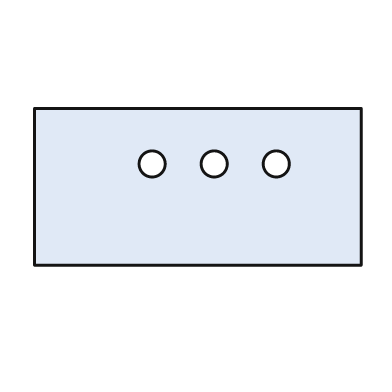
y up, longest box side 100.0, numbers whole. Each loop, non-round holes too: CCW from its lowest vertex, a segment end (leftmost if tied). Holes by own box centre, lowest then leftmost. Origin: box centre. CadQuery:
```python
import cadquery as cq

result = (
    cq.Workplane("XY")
    .moveTo(-50.0, -24.0)
    .lineTo(50.0, -24.0)
    .lineTo(50.0, 24.0)
    .lineTo(-50.0, 24.0)
    .close()
    .moveTo(-14.0, 7.0)
    .circle(4.0)
    .moveTo(5.0, 7.0)
    .circle(4.0)
    .moveTo(24.0, 7.0)
    .circle(4.0)
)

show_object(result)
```